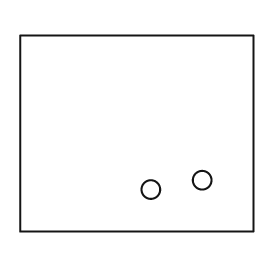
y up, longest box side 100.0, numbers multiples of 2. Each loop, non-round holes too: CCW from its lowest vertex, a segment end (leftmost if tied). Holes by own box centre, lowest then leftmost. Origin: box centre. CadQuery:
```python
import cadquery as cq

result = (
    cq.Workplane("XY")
    .moveTo(-50.0, -42.0)
    .lineTo(50.0, -42.0)
    .lineTo(50.0, 42.0)
    .lineTo(-50.0, 42.0)
    .close()
    .moveTo(6.0, -24.0)
    .circle(4.0)
    .moveTo(28.0, -20.0)
    .circle(4.0)
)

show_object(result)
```